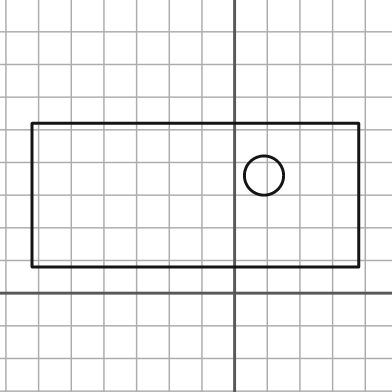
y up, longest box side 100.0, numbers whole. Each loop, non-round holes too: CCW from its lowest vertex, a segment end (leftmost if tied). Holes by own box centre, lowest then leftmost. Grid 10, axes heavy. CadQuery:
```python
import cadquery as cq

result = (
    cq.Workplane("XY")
    .moveTo(-62.0, 8.0)
    .lineTo(38.0, 8.0)
    .lineTo(38.0, 52.0)
    .lineTo(-62.0, 52.0)
    .close()
    .moveTo(9.0, 36.0)
    .circle(6.0)
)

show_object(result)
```